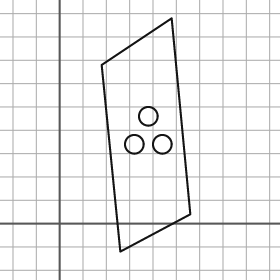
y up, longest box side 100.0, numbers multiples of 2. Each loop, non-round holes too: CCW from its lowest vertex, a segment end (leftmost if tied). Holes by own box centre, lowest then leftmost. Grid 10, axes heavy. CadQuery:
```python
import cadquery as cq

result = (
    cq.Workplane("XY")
    .moveTo(26.0, -12.0)
    .lineTo(56.0, 4.0)
    .lineTo(48.0, 88.0)
    .lineTo(18.0, 68.0)
    .close()
    .moveTo(32.0, 34.0)
    .circle(4.0)
    .moveTo(44.0, 34.0)
    .circle(4.0)
    .moveTo(38.0, 46.0)
    .circle(4.0)
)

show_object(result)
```